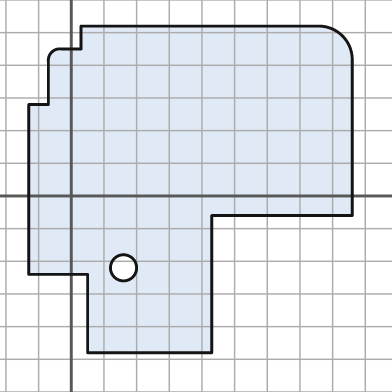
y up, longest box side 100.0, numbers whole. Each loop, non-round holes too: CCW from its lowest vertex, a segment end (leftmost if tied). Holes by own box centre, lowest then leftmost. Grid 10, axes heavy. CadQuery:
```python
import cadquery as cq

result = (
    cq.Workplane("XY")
    .moveTo(5.0, -48.0)
    .lineTo(43.0, -48.0)
    .lineTo(43.0, -6.0)
    .lineTo(86.0, -6.0)
    .lineTo(86.0, 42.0)
    .threePointArc((83.0, 49.0), (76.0, 52.0))
    .lineTo(3.0, 52.0)
    .lineTo(3.0, 45.0)
    .lineTo(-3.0, 45.0)
    .threePointArc((-6.0, 44.0), (-7.0, 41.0))
    .lineTo(-7.0, 28.0)
    .lineTo(-13.0, 28.0)
    .lineTo(-13.0, -24.0)
    .lineTo(5.0, -24.0)
    .close()
    .moveTo(16.0, -22.0)
    .circle(4.0)
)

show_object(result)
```